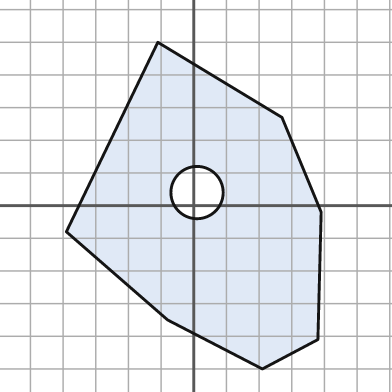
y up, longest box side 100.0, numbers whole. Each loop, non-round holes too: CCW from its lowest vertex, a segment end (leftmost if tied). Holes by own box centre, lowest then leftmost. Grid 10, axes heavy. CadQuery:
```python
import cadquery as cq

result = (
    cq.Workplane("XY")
    .moveTo(21.0, -50.0)
    .lineTo(38.0, -41.0)
    .lineTo(39.0, -2.0)
    .lineTo(27.0, 27.0)
    .lineTo(-11.0, 50.0)
    .lineTo(-39.0, -8.0)
    .lineTo(-8.0, -35.0)
    .close()
    .moveTo(1.0, 4.0)
    .circle(8.0)
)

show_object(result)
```